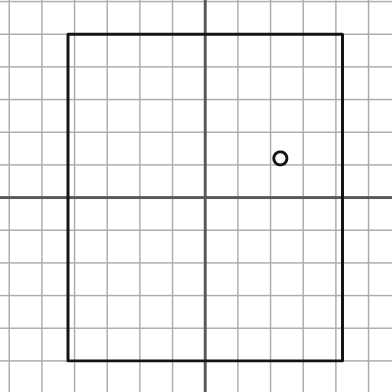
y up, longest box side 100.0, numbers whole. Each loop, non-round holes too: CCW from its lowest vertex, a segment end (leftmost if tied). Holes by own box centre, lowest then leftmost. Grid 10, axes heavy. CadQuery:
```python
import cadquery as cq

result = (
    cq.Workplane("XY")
    .moveTo(-42.0, -50.0)
    .lineTo(42.0, -50.0)
    .lineTo(42.0, 50.0)
    .lineTo(-42.0, 50.0)
    .close()
    .moveTo(23.0, 12.0)
    .circle(2.0)
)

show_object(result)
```